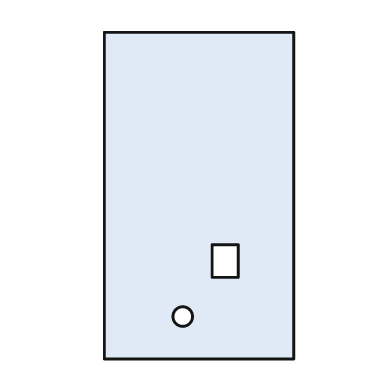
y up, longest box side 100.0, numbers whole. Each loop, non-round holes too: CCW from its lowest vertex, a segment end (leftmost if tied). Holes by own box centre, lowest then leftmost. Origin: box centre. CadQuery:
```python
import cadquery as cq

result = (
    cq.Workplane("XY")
    .moveTo(-29.0, -50.0)
    .lineTo(29.0, -50.0)
    .lineTo(29.0, 50.0)
    .lineTo(-29.0, 50.0)
    .close()
    .moveTo(-5.0, -37.0)
    .circle(3.0)
    .moveTo(4.0, -25.0)
    .lineTo(12.0, -25.0)
    .lineTo(12.0, -15.0)
    .lineTo(4.0, -15.0)
    .close()
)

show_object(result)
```